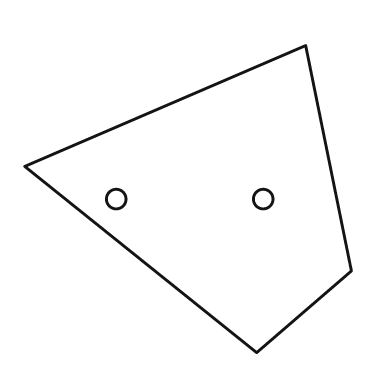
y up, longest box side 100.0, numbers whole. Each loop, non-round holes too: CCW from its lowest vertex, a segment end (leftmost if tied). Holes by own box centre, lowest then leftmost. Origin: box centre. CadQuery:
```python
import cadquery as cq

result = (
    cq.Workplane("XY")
    .moveTo(21.0, -47.0)
    .lineTo(50.0, -22.0)
    .lineTo(36.0, 47.0)
    .lineTo(-50.0, 10.0)
    .close()
    .moveTo(-22.0, 0.0)
    .circle(3.0)
    .moveTo(23.0, 0.0)
    .circle(3.0)
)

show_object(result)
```